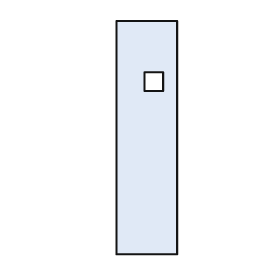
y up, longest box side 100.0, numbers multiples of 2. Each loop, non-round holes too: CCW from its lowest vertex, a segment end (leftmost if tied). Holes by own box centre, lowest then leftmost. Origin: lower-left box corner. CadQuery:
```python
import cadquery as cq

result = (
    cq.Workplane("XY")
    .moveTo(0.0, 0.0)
    .lineTo(26.0, 0.0)
    .lineTo(26.0, 100.0)
    .lineTo(0.0, 100.0)
    .close()
    .moveTo(12.0, 70.0)
    .lineTo(20.0, 70.0)
    .lineTo(20.0, 78.0)
    .lineTo(12.0, 78.0)
    .close()
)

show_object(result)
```